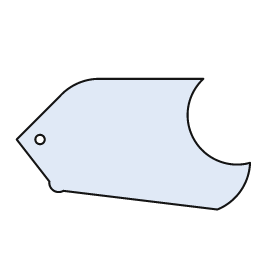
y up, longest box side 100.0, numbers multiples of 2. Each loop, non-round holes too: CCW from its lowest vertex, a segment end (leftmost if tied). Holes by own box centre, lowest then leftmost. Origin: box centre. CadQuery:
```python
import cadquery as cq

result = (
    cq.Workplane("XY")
    .moveTo(36.0, -28.0)
    .threePointArc((46.0, -20.0), (50.0, -8.0))
    .threePointArc((26.0, 2.0), (30.0, 28.0))
    .lineTo(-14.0, 28.0)
    .threePointArc((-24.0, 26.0), (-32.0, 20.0))
    .lineTo(-50.0, 2.0)
    .lineTo(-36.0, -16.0)
    .threePointArc((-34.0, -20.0), (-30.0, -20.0))
    .close()
    .moveTo(-40.0, 2.0)
    .circle(2.0)
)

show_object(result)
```